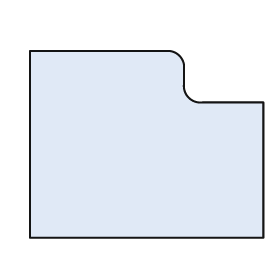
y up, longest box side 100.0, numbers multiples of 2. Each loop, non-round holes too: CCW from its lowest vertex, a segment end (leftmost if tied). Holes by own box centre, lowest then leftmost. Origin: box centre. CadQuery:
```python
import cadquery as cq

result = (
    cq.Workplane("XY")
    .moveTo(-50.0, -40.0)
    .lineTo(50.0, -40.0)
    .lineTo(50.0, 18.0)
    .lineTo(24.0, 18.0)
    .threePointArc((18.0, 20.0), (16.0, 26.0))
    .lineTo(16.0, 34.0)
    .threePointArc((14.0, 38.0), (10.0, 40.0))
    .lineTo(-50.0, 40.0)
    .close()
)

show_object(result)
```